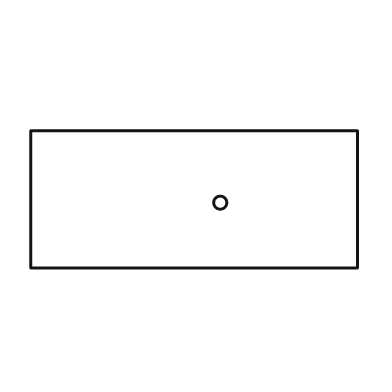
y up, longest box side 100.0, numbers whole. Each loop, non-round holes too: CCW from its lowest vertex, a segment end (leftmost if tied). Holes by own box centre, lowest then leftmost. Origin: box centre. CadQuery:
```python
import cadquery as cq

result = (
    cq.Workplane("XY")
    .moveTo(-50.0, -21.0)
    .lineTo(50.0, -21.0)
    .lineTo(50.0, 21.0)
    .lineTo(-50.0, 21.0)
    .close()
    .moveTo(8.0, -1.0)
    .circle(2.0)
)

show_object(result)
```